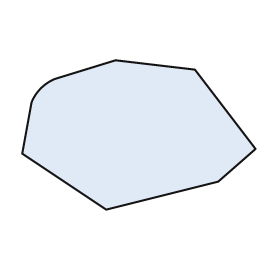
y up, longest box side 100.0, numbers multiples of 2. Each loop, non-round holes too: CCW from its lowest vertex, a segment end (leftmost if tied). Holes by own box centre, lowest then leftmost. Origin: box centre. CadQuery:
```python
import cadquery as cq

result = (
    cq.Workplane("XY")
    .moveTo(-14.0, -32.0)
    .lineTo(34.0, -20.0)
    .lineTo(50.0, -6.0)
    .lineTo(24.0, 28.0)
    .lineTo(-10.0, 32.0)
    .lineTo(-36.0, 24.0)
    .threePointArc((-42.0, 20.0), (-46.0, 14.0))
    .lineTo(-50.0, -8.0)
    .close()
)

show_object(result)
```